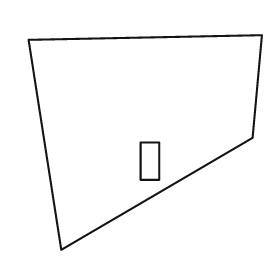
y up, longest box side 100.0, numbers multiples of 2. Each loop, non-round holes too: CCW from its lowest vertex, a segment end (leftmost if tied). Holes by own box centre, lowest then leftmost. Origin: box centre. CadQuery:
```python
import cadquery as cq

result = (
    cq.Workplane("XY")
    .moveTo(-36.0, -46.0)
    .lineTo(46.0, 2.0)
    .lineTo(50.0, 46.0)
    .lineTo(-50.0, 44.0)
    .close()
    .moveTo(-2.0, -16.0)
    .lineTo(6.0, -16.0)
    .lineTo(6.0, 0.0)
    .lineTo(-2.0, 0.0)
    .close()
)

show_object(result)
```